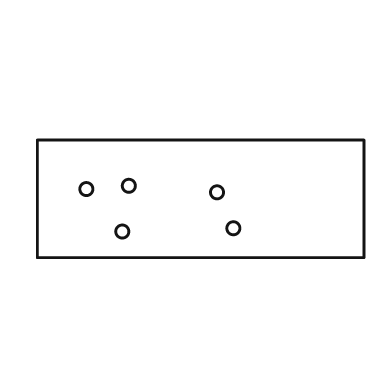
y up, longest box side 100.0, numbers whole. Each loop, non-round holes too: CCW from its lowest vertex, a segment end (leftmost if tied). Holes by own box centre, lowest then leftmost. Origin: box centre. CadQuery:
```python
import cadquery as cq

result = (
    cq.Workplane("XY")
    .moveTo(-50.0, -18.0)
    .lineTo(50.0, -18.0)
    .lineTo(50.0, 18.0)
    .lineTo(-50.0, 18.0)
    .close()
    .moveTo(-24.0, -10.0)
    .circle(2.0)
    .moveTo(10.0, -9.0)
    .circle(2.0)
    .moveTo(5.0, 2.0)
    .circle(2.0)
    .moveTo(-35.0, 3.0)
    .circle(2.0)
    .moveTo(-22.0, 4.0)
    .circle(2.0)
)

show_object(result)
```